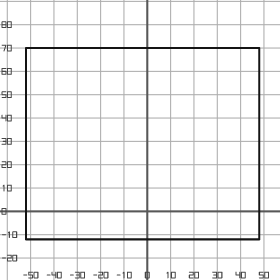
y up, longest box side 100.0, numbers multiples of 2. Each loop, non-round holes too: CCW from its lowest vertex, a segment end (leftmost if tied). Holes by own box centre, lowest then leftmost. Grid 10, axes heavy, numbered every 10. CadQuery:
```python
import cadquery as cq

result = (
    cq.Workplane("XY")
    .moveTo(-52.0, -12.0)
    .lineTo(48.0, -12.0)
    .lineTo(48.0, 70.0)
    .lineTo(-52.0, 70.0)
    .close()
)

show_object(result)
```